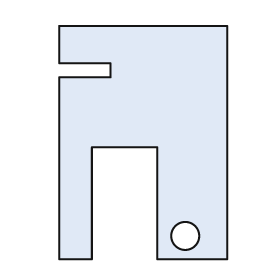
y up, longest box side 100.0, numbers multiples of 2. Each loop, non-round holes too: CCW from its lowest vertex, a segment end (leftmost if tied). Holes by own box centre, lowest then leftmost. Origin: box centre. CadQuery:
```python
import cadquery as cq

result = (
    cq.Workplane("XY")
    .moveTo(-36.0, -50.0)
    .lineTo(-22.0, -50.0)
    .lineTo(-22.0, -2.0)
    .lineTo(6.0, -2.0)
    .lineTo(6.0, -50.0)
    .lineTo(36.0, -50.0)
    .lineTo(36.0, 50.0)
    .lineTo(-36.0, 50.0)
    .lineTo(-36.0, 34.0)
    .lineTo(-14.0, 34.0)
    .lineTo(-14.0, 28.0)
    .lineTo(-36.0, 28.0)
    .close()
    .moveTo(18.0, -40.0)
    .circle(6.0)
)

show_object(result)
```